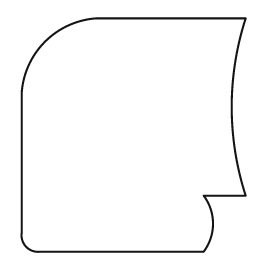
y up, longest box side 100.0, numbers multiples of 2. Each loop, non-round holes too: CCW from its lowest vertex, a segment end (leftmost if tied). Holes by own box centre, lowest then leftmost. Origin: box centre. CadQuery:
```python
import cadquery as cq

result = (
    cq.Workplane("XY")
    .moveTo(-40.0, -50.0)
    .lineTo(30.0, -50.0)
    .threePointArc((34.0, -38.0), (30.0, -26.0))
    .lineTo(48.0, -26.0)
    .threePointArc((42.0, 12.0), (48.0, 50.0))
    .lineTo(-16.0, 50.0)
    .threePointArc((-38.0, 40.0), (-48.0, 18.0))
    .lineTo(-48.0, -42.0)
    .threePointArc((-46.0, -48.0), (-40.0, -50.0))
    .close()
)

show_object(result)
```